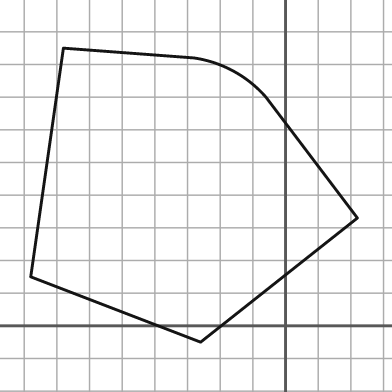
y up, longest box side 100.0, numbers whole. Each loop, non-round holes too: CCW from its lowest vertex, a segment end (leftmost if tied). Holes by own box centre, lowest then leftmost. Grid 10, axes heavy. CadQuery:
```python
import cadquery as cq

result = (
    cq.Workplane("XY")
    .moveTo(-26.0, -5.0)
    .lineTo(22.0, 33.0)
    .lineTo(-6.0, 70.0)
    .threePointArc((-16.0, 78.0), (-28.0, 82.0))
    .lineTo(-68.0, 85.0)
    .lineTo(-78.0, 15.0)
    .close()
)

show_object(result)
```